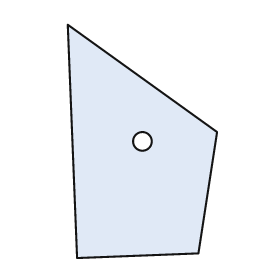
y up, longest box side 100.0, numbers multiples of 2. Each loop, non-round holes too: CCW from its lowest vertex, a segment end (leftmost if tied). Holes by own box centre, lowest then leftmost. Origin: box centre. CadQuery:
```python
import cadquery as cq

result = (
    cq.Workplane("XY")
    .moveTo(-28.0, -50.0)
    .lineTo(24.0, -48.0)
    .lineTo(32.0, 4.0)
    .lineTo(-32.0, 50.0)
    .close()
    .moveTo(0.0, 0.0)
    .circle(4.0)
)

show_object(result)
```